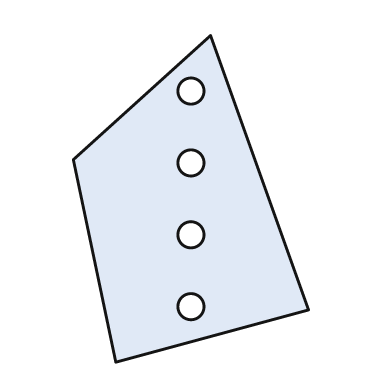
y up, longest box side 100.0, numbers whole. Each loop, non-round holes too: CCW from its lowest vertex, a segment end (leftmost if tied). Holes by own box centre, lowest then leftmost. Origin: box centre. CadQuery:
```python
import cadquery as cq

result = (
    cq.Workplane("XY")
    .moveTo(-23.0, -50.0)
    .lineTo(36.0, -34.0)
    .lineTo(6.0, 50.0)
    .lineTo(-36.0, 12.0)
    .close()
    .moveTo(0.0, -33.0)
    .circle(4.0)
    .moveTo(0.0, -11.0)
    .circle(4.0)
    .moveTo(0.0, 11.0)
    .circle(4.0)
    .moveTo(0.0, 33.0)
    .circle(4.0)
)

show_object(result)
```